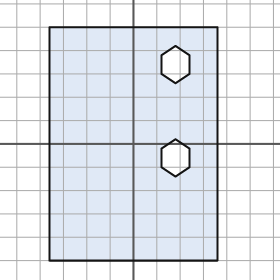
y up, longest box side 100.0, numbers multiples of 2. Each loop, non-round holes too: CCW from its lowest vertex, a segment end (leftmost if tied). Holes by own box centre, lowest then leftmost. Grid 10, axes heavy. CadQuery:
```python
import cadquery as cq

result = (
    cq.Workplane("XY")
    .moveTo(-36.0, -50.0)
    .lineTo(36.0, -50.0)
    .lineTo(36.0, 50.0)
    .lineTo(-36.0, 50.0)
    .close()
    .moveTo(18.0, -14.0)
    .lineTo(24.0, -10.0)
    .lineTo(24.0, -2.0)
    .lineTo(18.0, 2.0)
    .lineTo(12.0, -2.0)
    .lineTo(12.0, -10.0)
    .close()
    .moveTo(18.0, 26.0)
    .lineTo(24.0, 30.0)
    .lineTo(24.0, 38.0)
    .lineTo(18.0, 42.0)
    .lineTo(12.0, 38.0)
    .lineTo(12.0, 30.0)
    .close()
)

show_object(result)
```